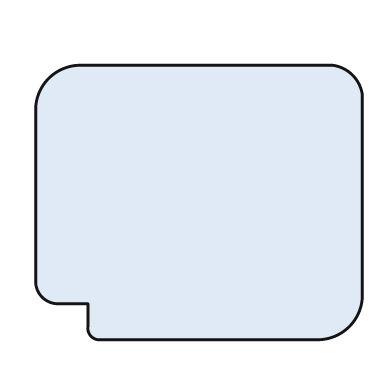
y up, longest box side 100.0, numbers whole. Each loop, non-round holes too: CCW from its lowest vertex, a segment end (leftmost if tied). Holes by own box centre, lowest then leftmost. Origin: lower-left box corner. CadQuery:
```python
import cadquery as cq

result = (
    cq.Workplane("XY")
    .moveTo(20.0, 0.0)
    .lineTo(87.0, 0.0)
    .threePointArc((96.0, 4.0), (100.0, 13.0))
    .lineTo(100.0, 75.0)
    .threePointArc((97.0, 81.0), (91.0, 84.0))
    .lineTo(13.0, 84.0)
    .threePointArc((4.0, 80.0), (0.0, 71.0))
    .lineTo(0.0, 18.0)
    .threePointArc((2.0, 13.0), (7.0, 11.0))
    .lineTo(16.0, 11.0)
    .lineTo(16.0, 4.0)
    .threePointArc((17.0, 1.0), (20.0, 0.0))
    .close()
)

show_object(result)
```